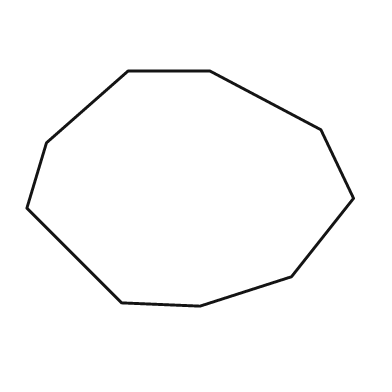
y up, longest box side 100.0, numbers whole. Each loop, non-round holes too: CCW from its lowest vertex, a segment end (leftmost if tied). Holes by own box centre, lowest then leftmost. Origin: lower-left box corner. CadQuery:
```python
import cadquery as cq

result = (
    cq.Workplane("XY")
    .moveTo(53.0, 0.0)
    .lineTo(81.0, 9.0)
    .lineTo(100.0, 33.0)
    .lineTo(90.0, 54.0)
    .lineTo(56.0, 72.0)
    .lineTo(31.0, 72.0)
    .lineTo(6.0, 50.0)
    .lineTo(0.0, 30.0)
    .lineTo(29.0, 1.0)
    .close()
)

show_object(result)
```